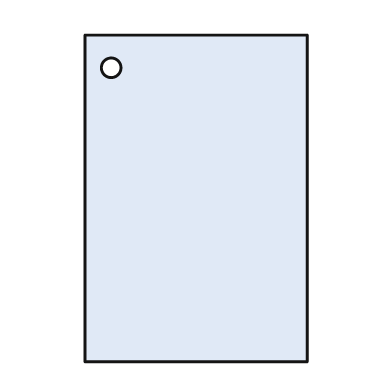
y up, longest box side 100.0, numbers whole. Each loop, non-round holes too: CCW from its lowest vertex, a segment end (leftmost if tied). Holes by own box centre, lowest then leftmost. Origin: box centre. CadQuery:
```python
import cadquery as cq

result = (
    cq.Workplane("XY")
    .moveTo(-34.0, -50.0)
    .lineTo(34.0, -50.0)
    .lineTo(34.0, 50.0)
    .lineTo(-34.0, 50.0)
    .close()
    .moveTo(-26.0, 40.0)
    .circle(3.0)
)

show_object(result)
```